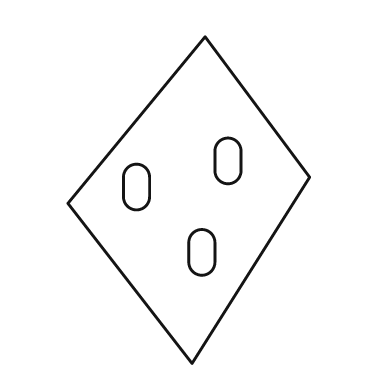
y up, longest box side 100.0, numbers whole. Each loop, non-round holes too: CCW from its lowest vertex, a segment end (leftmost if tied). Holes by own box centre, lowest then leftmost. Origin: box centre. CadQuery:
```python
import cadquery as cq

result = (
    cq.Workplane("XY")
    .moveTo(1.0, -50.0)
    .lineTo(37.0, 7.0)
    .lineTo(5.0, 50.0)
    .lineTo(-37.0, -1.0)
    .close()
    .moveTo(0.0, -19.0)
    .threePointArc((4.0, -23.0), (8.0, -19.0))
    .lineTo(8.0, -13.0)
    .threePointArc((4.0, -9.0), (0.0, -13.0))
    .close()
    .moveTo(-20.0, 1.0)
    .threePointArc((-16.0, -3.0), (-12.0, 1.0))
    .lineTo(-12.0, 7.0)
    .threePointArc((-16.0, 11.0), (-20.0, 7.0))
    .close()
    .moveTo(8.0, 9.0)
    .threePointArc((12.0, 5.0), (16.0, 9.0))
    .lineTo(16.0, 15.0)
    .threePointArc((12.0, 19.0), (8.0, 15.0))
    .close()
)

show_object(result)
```